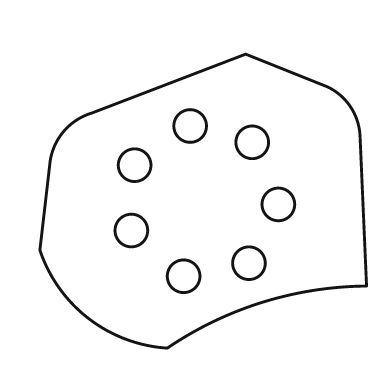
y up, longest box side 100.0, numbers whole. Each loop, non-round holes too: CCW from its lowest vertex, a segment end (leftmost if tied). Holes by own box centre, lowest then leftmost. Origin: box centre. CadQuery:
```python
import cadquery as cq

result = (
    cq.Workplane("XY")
    .moveTo(-11.0, -45.0)
    .threePointArc((18.0, -31.0), (50.0, -26.0))
    .lineTo(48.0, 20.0)
    .threePointArc((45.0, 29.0), (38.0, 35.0))
    .lineTo(13.0, 45.0)
    .lineTo(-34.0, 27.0)
    .threePointArc((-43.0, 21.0), (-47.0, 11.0))
    .lineTo(-50.0, -15.0)
    .threePointArc((-35.0, -36.0), (-11.0, -45.0))
    .close()
    .moveTo(-6.0, -23.0)
    .circle(5.0)
    .moveTo(14.0, -19.0)
    .circle(5.0)
    .moveTo(-22.0, -9.0)
    .circle(5.0)
    .moveTo(23.0, -1.0)
    .circle(5.0)
    .moveTo(-21.0, 11.0)
    .circle(5.0)
    .moveTo(15.0, 18.0)
    .circle(5.0)
    .moveTo(-4.0, 23.0)
    .circle(5.0)
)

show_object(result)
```